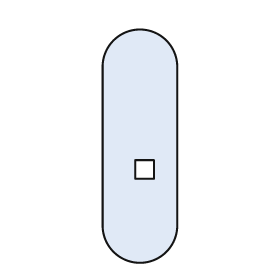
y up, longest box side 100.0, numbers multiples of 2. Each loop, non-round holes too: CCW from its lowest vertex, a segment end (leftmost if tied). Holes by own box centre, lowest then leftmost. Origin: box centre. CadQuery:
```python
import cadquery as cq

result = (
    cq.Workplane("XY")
    .moveTo(-16.0, -34.0)
    .threePointArc((0.0, -50.0), (16.0, -34.0))
    .lineTo(16.0, 34.0)
    .threePointArc((0.0, 50.0), (-16.0, 34.0))
    .close()
    .moveTo(-2.0, -14.0)
    .lineTo(6.0, -14.0)
    .lineTo(6.0, -6.0)
    .lineTo(-2.0, -6.0)
    .close()
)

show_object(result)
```